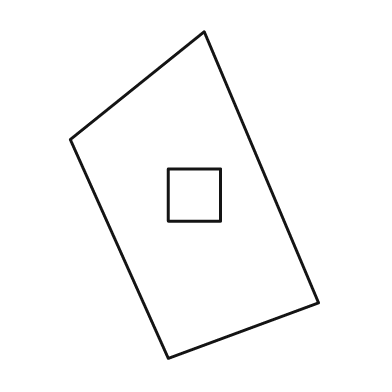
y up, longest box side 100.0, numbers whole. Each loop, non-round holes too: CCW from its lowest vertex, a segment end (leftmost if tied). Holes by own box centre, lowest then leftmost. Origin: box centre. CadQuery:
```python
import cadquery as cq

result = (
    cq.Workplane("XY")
    .moveTo(-8.0, -50.0)
    .lineTo(38.0, -33.0)
    .lineTo(3.0, 50.0)
    .lineTo(-38.0, 17.0)
    .close()
    .moveTo(-8.0, -8.0)
    .lineTo(8.0, -8.0)
    .lineTo(8.0, 8.0)
    .lineTo(-8.0, 8.0)
    .close()
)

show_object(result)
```